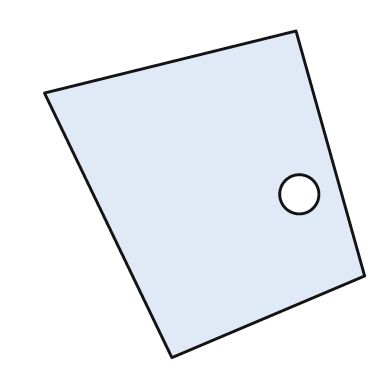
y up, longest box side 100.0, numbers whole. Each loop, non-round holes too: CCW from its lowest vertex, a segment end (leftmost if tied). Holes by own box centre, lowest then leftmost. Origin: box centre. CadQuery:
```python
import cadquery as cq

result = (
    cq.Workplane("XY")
    .moveTo(-10.0, -50.0)
    .lineTo(49.0, -25.0)
    .lineTo(28.0, 50.0)
    .lineTo(-49.0, 31.0)
    .close()
    .moveTo(29.0, 0.0)
    .circle(6.0)
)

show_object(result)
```